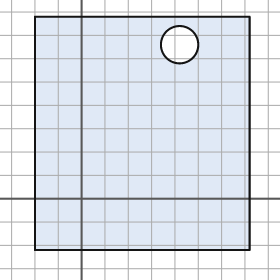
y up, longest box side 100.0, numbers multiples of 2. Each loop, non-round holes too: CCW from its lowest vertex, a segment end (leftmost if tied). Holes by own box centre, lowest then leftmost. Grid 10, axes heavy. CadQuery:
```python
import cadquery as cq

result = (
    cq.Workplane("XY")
    .moveTo(-20.0, -22.0)
    .lineTo(72.0, -22.0)
    .lineTo(72.0, 78.0)
    .lineTo(-20.0, 78.0)
    .close()
    .moveTo(42.0, 66.0)
    .circle(8.0)
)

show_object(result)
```